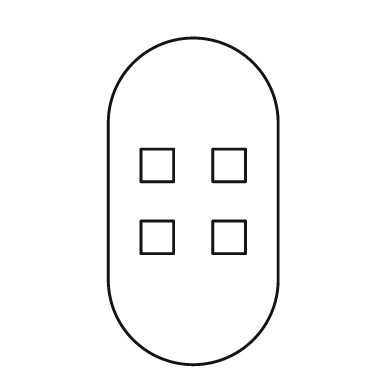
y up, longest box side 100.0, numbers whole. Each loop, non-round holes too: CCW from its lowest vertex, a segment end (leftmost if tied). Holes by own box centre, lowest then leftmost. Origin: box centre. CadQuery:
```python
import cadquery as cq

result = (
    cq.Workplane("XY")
    .moveTo(-26.0, -24.0)
    .threePointArc((0.0, -50.0), (26.0, -24.0))
    .lineTo(26.0, 24.0)
    .threePointArc((0.0, 50.0), (-26.0, 24.0))
    .close()
    .moveTo(-16.0, -16.0)
    .lineTo(-6.0, -16.0)
    .lineTo(-6.0, -6.0)
    .lineTo(-16.0, -6.0)
    .close()
    .moveTo(6.0, -16.0)
    .lineTo(16.0, -16.0)
    .lineTo(16.0, -6.0)
    .lineTo(6.0, -6.0)
    .close()
    .moveTo(-16.0, 6.0)
    .lineTo(-6.0, 6.0)
    .lineTo(-6.0, 16.0)
    .lineTo(-16.0, 16.0)
    .close()
    .moveTo(6.0, 6.0)
    .lineTo(16.0, 6.0)
    .lineTo(16.0, 16.0)
    .lineTo(6.0, 16.0)
    .close()
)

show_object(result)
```